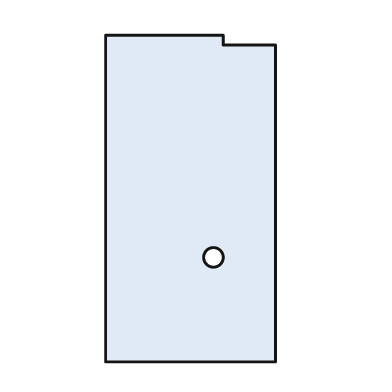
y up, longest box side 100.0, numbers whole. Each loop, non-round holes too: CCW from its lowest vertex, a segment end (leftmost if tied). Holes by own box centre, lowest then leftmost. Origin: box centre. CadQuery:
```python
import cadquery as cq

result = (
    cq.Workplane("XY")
    .moveTo(-26.0, -50.0)
    .lineTo(26.0, -50.0)
    .lineTo(26.0, 47.0)
    .lineTo(10.0, 47.0)
    .lineTo(10.0, 50.0)
    .lineTo(-26.0, 50.0)
    .close()
    .moveTo(7.0, -18.0)
    .circle(3.0)
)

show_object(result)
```